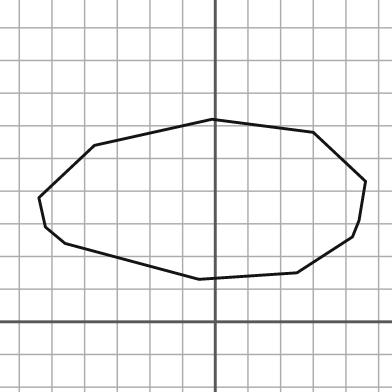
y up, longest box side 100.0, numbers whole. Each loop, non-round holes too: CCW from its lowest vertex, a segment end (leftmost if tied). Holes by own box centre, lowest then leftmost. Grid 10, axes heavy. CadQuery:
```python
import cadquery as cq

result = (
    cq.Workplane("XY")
    .moveTo(-5.0, 13.0)
    .lineTo(25.0, 15.0)
    .lineTo(42.0, 26.0)
    .lineTo(44.0, 31.0)
    .lineTo(46.0, 43.0)
    .lineTo(30.0, 58.0)
    .lineTo(-1.0, 62.0)
    .lineTo(-37.0, 54.0)
    .lineTo(-54.0, 38.0)
    .lineTo(-52.0, 29.0)
    .lineTo(-46.0, 24.0)
    .close()
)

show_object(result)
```